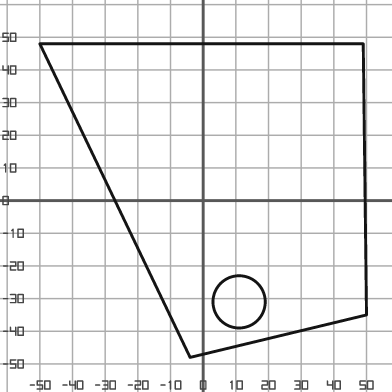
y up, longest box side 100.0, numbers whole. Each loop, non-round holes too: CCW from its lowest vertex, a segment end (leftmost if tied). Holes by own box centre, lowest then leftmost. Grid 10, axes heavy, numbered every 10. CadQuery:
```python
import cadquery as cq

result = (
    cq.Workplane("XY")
    .moveTo(-4.0, -48.0)
    .lineTo(50.0, -35.0)
    .lineTo(49.0, 48.0)
    .lineTo(-50.0, 48.0)
    .close()
    .moveTo(11.0, -31.0)
    .circle(8.0)
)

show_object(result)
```